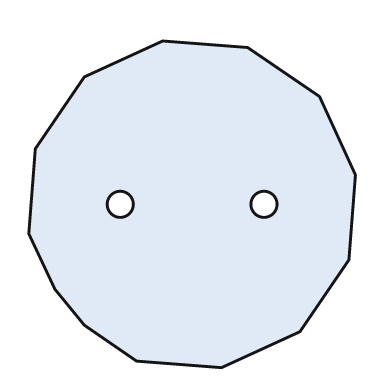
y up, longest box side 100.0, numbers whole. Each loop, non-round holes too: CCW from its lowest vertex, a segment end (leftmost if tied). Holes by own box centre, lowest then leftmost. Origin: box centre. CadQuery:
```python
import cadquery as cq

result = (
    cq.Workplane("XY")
    .moveTo(9.0, -50.0)
    .lineTo(33.0, -39.0)
    .lineTo(48.0, -17.0)
    .lineTo(50.0, 9.0)
    .lineTo(39.0, 33.0)
    .lineTo(17.0, 48.0)
    .lineTo(-9.0, 50.0)
    .lineTo(-33.0, 39.0)
    .lineTo(-48.0, 17.0)
    .lineTo(-50.0, -9.0)
    .lineTo(-42.0, -26.0)
    .lineTo(-33.0, -37.0)
    .lineTo(-17.0, -48.0)
    .close()
    .moveTo(-22.0, 0.0)
    .circle(4.0)
    .moveTo(22.0, 0.0)
    .circle(4.0)
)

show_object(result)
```